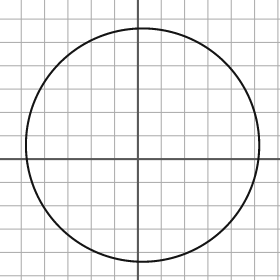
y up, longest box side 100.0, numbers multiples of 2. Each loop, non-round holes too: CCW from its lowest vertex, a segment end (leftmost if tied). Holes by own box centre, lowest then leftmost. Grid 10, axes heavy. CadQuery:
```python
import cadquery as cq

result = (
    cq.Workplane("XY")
    .moveTo(2.0, 6.0)
    .circle(50.0)
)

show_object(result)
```